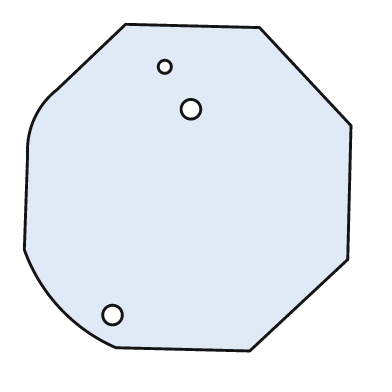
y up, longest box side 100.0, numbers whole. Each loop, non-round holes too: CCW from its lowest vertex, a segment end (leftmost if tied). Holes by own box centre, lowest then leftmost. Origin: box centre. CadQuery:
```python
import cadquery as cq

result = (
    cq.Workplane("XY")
    .moveTo(19.0, -50.0)
    .lineTo(49.0, -22.0)
    .lineTo(50.0, 19.0)
    .lineTo(22.0, 49.0)
    .lineTo(-19.0, 50.0)
    .lineTo(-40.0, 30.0)
    .threePointArc((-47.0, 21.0), (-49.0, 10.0))
    .lineTo(-50.0, -19.0)
    .threePointArc((-39.0, -37.0), (-22.0, -49.0))
    .close()
    .moveTo(-23.0, -39.0)
    .circle(3.0)
    .moveTo(1.0, 24.0)
    .circle(3.0)
    .moveTo(-7.0, 37.0)
    .circle(2.0)
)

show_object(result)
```